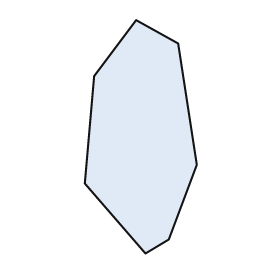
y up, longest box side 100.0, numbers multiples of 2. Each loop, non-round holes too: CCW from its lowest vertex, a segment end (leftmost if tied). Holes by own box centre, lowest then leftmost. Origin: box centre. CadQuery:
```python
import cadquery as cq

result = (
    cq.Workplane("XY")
    .moveTo(2.0, -50.0)
    .lineTo(12.0, -44.0)
    .lineTo(24.0, -12.0)
    .lineTo(16.0, 40.0)
    .lineTo(-2.0, 50.0)
    .lineTo(-20.0, 26.0)
    .lineTo(-24.0, -20.0)
    .close()
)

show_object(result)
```